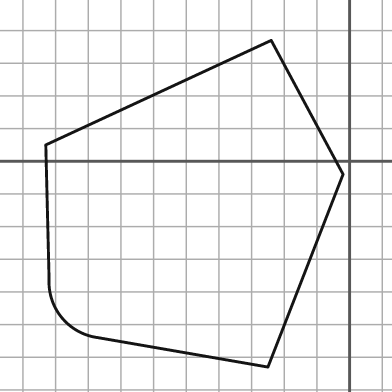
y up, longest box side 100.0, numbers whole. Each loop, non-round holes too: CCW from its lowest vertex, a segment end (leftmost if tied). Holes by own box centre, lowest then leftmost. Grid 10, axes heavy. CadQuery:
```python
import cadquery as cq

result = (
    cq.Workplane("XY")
    .moveTo(-25.0, -63.0)
    .lineTo(-2.0, -4.0)
    .lineTo(-24.0, 37.0)
    .lineTo(-93.0, 5.0)
    .lineTo(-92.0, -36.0)
    .threePointArc((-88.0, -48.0), (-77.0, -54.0))
    .close()
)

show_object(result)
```